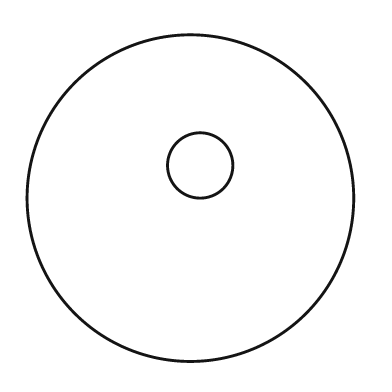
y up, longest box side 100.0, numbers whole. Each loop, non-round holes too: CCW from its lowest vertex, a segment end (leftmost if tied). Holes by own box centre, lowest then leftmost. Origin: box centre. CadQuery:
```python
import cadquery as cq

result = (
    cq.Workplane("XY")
    .moveTo(0.0, 0.0)
    .circle(50.0)
    .moveTo(3.0, 10.0)
    .circle(10.0)
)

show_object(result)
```